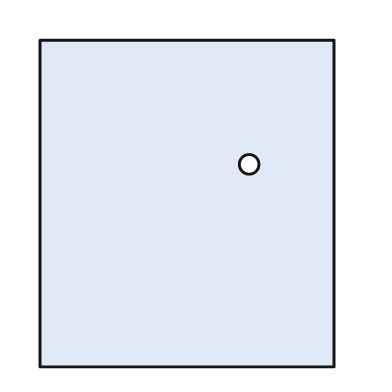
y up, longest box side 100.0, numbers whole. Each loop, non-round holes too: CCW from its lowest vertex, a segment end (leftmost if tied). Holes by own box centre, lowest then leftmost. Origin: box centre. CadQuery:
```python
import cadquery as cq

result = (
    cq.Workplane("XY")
    .moveTo(-45.0, -50.0)
    .lineTo(45.0, -50.0)
    .lineTo(45.0, 50.0)
    .lineTo(-45.0, 50.0)
    .close()
    .moveTo(19.0, 12.0)
    .circle(3.0)
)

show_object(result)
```